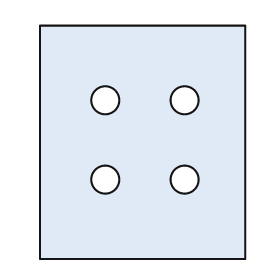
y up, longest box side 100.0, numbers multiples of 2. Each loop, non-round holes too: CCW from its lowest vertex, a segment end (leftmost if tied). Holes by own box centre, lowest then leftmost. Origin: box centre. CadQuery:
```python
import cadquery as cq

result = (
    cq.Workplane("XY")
    .moveTo(-44.0, -50.0)
    .lineTo(44.0, -50.0)
    .lineTo(44.0, 50.0)
    .lineTo(-44.0, 50.0)
    .close()
    .moveTo(-16.0, -16.0)
    .circle(6.0)
    .moveTo(18.0, -16.0)
    .circle(6.0)
    .moveTo(-16.0, 18.0)
    .circle(6.0)
    .moveTo(18.0, 18.0)
    .circle(6.0)
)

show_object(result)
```